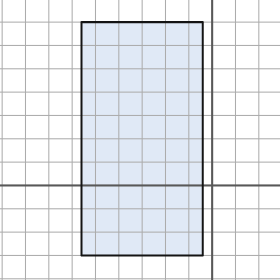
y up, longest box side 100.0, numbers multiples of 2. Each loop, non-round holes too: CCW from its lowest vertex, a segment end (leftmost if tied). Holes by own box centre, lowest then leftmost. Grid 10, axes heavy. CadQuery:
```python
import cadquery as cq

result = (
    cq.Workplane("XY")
    .moveTo(-56.0, -30.0)
    .lineTo(-4.0, -30.0)
    .lineTo(-4.0, 70.0)
    .lineTo(-56.0, 70.0)
    .close()
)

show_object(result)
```